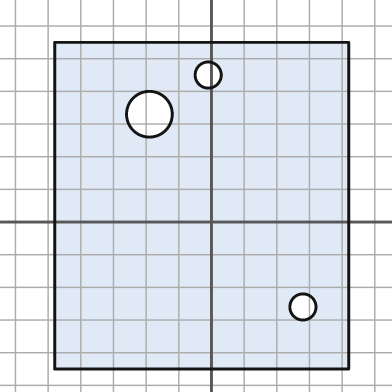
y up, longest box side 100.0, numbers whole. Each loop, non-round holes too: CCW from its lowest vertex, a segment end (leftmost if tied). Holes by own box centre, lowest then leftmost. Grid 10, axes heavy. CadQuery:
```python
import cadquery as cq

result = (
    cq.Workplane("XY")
    .moveTo(-48.0, -45.0)
    .lineTo(42.0, -45.0)
    .lineTo(42.0, 55.0)
    .lineTo(-48.0, 55.0)
    .close()
    .moveTo(28.0, -26.0)
    .circle(4.0)
    .moveTo(-19.0, 33.0)
    .circle(7.0)
    .moveTo(-1.0, 45.0)
    .circle(4.0)
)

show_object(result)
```